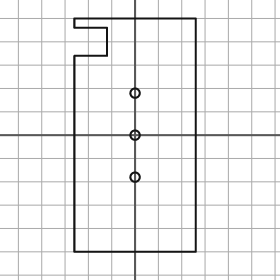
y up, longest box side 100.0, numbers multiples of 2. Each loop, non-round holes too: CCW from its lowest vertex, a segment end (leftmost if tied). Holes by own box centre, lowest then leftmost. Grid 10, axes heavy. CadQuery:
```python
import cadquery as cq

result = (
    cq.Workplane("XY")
    .moveTo(-26.0, -50.0)
    .lineTo(26.0, -50.0)
    .lineTo(26.0, 50.0)
    .lineTo(-26.0, 50.0)
    .lineTo(-26.0, 46.0)
    .lineTo(-12.0, 46.0)
    .lineTo(-12.0, 34.0)
    .lineTo(-26.0, 34.0)
    .close()
    .moveTo(0.0, -18.0)
    .circle(2.0)
    .moveTo(0.0, 0.0)
    .circle(2.0)
    .moveTo(0.0, 18.0)
    .circle(2.0)
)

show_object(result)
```